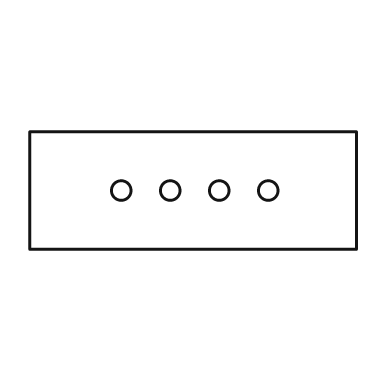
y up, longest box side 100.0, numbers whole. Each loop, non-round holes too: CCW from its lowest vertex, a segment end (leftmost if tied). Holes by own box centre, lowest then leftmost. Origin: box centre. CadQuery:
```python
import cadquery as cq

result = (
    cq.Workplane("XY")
    .moveTo(-50.0, -18.0)
    .lineTo(50.0, -18.0)
    .lineTo(50.0, 18.0)
    .lineTo(-50.0, 18.0)
    .close()
    .moveTo(-22.0, 0.0)
    .circle(3.0)
    .moveTo(-7.0, 0.0)
    .circle(3.0)
    .moveTo(8.0, 0.0)
    .circle(3.0)
    .moveTo(23.0, 0.0)
    .circle(3.0)
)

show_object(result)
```